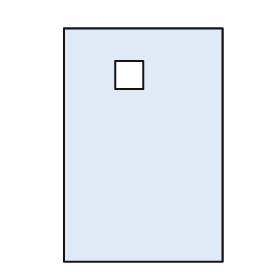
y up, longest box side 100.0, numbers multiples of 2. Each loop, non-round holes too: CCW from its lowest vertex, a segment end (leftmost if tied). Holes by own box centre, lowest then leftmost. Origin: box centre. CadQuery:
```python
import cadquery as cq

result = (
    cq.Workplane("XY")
    .moveTo(-34.0, -50.0)
    .lineTo(34.0, -50.0)
    .lineTo(34.0, 50.0)
    .lineTo(-34.0, 50.0)
    .close()
    .moveTo(-12.0, 24.0)
    .lineTo(0.0, 24.0)
    .lineTo(0.0, 36.0)
    .lineTo(-12.0, 36.0)
    .close()
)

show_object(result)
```